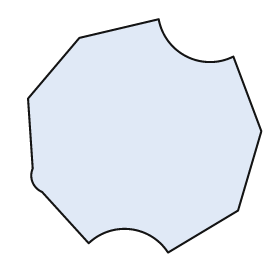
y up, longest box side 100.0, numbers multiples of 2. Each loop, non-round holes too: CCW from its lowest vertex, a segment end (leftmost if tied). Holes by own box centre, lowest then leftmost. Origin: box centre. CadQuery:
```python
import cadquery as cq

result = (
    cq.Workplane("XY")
    .moveTo(10.0, -50.0)
    .lineTo(40.0, -32.0)
    .lineTo(50.0, 2.0)
    .lineTo(38.0, 34.0)
    .threePointArc((18.0, 34.0), (6.0, 50.0))
    .lineTo(-28.0, 42.0)
    .lineTo(-50.0, 16.0)
    .lineTo(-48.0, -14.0)
    .threePointArc((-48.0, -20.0), (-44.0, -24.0))
    .lineTo(-24.0, -46.0)
    .threePointArc((-6.0, -40.0), (10.0, -50.0))
    .close()
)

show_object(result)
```